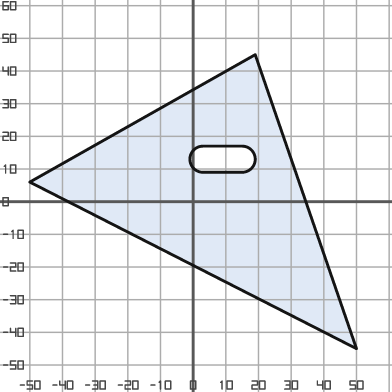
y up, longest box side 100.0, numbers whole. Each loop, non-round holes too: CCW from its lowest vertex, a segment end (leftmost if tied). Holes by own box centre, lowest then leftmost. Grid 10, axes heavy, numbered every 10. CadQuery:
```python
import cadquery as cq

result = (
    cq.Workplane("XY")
    .moveTo(50.0, -45.0)
    .lineTo(19.0, 45.0)
    .lineTo(-50.0, 6.0)
    .close()
    .moveTo(3.0, 9.0)
    .lineTo(15.0, 9.0)
    .threePointArc((19.0, 13.0), (15.0, 17.0))
    .lineTo(3.0, 17.0)
    .threePointArc((-1.0, 13.0), (3.0, 9.0))
    .close()
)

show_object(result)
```